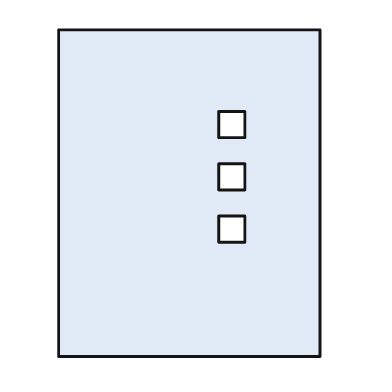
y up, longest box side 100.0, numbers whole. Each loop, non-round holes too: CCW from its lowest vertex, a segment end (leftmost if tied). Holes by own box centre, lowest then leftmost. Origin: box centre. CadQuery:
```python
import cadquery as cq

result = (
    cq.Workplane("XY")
    .moveTo(-40.0, -50.0)
    .lineTo(40.0, -50.0)
    .lineTo(40.0, 50.0)
    .lineTo(-40.0, 50.0)
    .close()
    .moveTo(9.0, -15.0)
    .lineTo(17.0, -15.0)
    .lineTo(17.0, -7.0)
    .lineTo(9.0, -7.0)
    .close()
    .moveTo(9.0, 1.0)
    .lineTo(17.0, 1.0)
    .lineTo(17.0, 9.0)
    .lineTo(9.0, 9.0)
    .close()
    .moveTo(9.0, 17.0)
    .lineTo(17.0, 17.0)
    .lineTo(17.0, 25.0)
    .lineTo(9.0, 25.0)
    .close()
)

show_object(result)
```